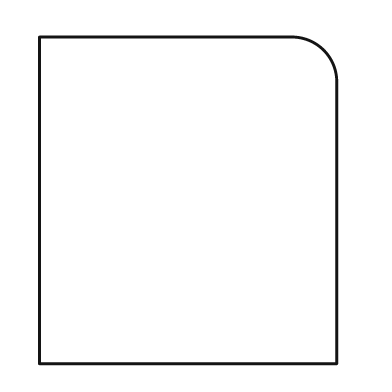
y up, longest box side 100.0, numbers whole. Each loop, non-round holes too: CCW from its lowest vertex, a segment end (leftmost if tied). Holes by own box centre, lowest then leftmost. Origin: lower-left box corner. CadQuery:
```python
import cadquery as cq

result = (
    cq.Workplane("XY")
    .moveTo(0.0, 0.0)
    .lineTo(91.0, 0.0)
    .lineTo(91.0, 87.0)
    .threePointArc((87.0, 96.0), (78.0, 100.0))
    .lineTo(0.0, 100.0)
    .close()
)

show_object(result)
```